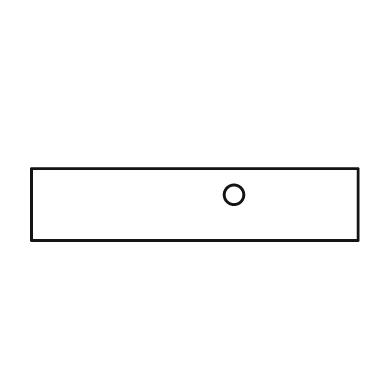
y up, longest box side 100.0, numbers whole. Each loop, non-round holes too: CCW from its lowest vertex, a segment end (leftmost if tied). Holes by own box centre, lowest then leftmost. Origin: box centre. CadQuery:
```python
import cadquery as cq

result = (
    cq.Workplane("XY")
    .moveTo(-50.0, -11.0)
    .lineTo(50.0, -11.0)
    .lineTo(50.0, 11.0)
    .lineTo(-50.0, 11.0)
    .close()
    .moveTo(12.0, 3.0)
    .circle(3.0)
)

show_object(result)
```